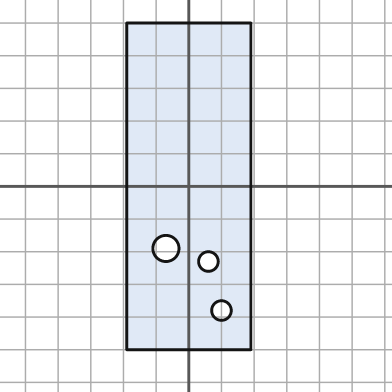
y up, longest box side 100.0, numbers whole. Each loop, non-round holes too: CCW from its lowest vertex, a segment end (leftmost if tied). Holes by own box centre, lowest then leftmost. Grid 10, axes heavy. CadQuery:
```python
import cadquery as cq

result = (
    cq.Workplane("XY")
    .moveTo(-19.0, -50.0)
    .lineTo(19.0, -50.0)
    .lineTo(19.0, 50.0)
    .lineTo(-19.0, 50.0)
    .close()
    .moveTo(10.0, -38.0)
    .circle(3.0)
    .moveTo(6.0, -23.0)
    .circle(3.0)
    .moveTo(-7.0, -19.0)
    .circle(4.0)
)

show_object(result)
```